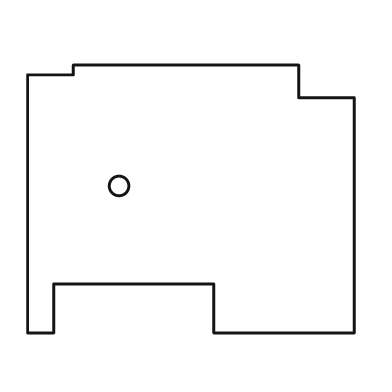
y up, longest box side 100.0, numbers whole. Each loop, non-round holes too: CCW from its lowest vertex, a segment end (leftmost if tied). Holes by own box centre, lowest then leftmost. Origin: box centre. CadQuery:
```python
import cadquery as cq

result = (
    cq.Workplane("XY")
    .moveTo(-50.0, -41.0)
    .lineTo(-42.0, -41.0)
    .lineTo(-42.0, -26.0)
    .lineTo(7.0, -26.0)
    .lineTo(7.0, -41.0)
    .lineTo(50.0, -41.0)
    .lineTo(50.0, 31.0)
    .lineTo(33.0, 31.0)
    .lineTo(33.0, 41.0)
    .lineTo(-36.0, 41.0)
    .lineTo(-36.0, 38.0)
    .lineTo(-50.0, 38.0)
    .close()
    .moveTo(-22.0, 4.0)
    .circle(3.0)
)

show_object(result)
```